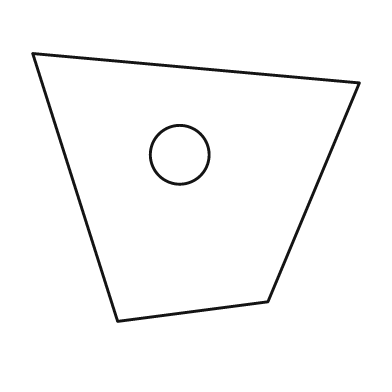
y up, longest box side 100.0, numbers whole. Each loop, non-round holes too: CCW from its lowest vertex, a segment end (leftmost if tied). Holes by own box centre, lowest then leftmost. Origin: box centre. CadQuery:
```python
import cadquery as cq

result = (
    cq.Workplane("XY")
    .moveTo(-24.0, -41.0)
    .lineTo(22.0, -35.0)
    .lineTo(50.0, 32.0)
    .lineTo(-50.0, 41.0)
    .close()
    .moveTo(-5.0, 10.0)
    .circle(9.0)
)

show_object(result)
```